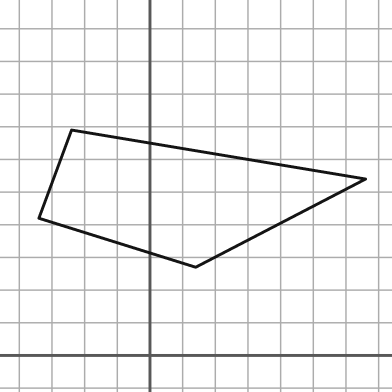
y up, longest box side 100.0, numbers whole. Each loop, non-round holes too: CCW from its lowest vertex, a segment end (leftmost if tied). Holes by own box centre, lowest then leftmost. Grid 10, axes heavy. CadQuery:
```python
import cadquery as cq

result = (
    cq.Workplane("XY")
    .moveTo(14.0, 27.0)
    .lineTo(66.0, 54.0)
    .lineTo(-24.0, 69.0)
    .lineTo(-34.0, 42.0)
    .close()
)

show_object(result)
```